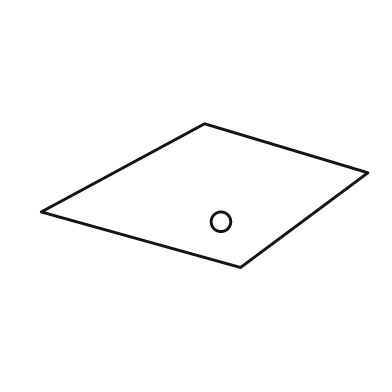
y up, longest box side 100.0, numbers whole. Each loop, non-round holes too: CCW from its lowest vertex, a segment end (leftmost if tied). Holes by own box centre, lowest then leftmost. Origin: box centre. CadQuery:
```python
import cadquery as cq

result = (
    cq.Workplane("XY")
    .moveTo(11.0, -22.0)
    .lineTo(50.0, 7.0)
    .lineTo(0.0, 22.0)
    .lineTo(-50.0, -5.0)
    .close()
    .moveTo(5.0, -8.0)
    .circle(3.0)
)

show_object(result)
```